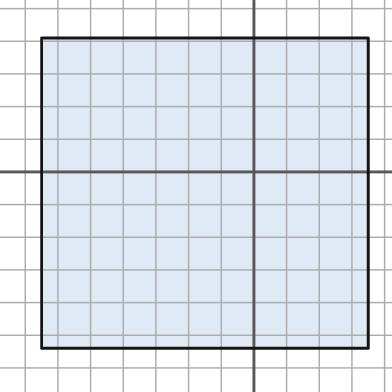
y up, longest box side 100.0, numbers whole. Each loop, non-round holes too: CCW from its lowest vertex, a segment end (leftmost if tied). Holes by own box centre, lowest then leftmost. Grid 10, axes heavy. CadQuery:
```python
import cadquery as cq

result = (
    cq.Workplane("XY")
    .moveTo(-65.0, -54.0)
    .lineTo(35.0, -54.0)
    .lineTo(35.0, 41.0)
    .lineTo(-65.0, 41.0)
    .close()
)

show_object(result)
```